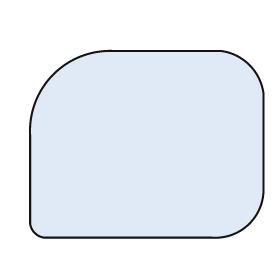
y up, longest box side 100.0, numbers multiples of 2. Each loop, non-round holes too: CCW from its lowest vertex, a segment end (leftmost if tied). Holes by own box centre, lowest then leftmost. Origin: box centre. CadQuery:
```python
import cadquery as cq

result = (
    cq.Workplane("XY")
    .moveTo(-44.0, -40.0)
    .lineTo(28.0, -40.0)
    .threePointArc((44.0, -34.0), (50.0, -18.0))
    .lineTo(50.0, 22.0)
    .threePointArc((44.0, 34.0), (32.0, 40.0))
    .lineTo(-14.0, 40.0)
    .threePointArc((-40.0, 30.0), (-50.0, 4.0))
    .lineTo(-50.0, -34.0)
    .threePointArc((-48.0, -38.0), (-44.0, -40.0))
    .close()
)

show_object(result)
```